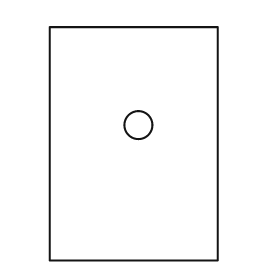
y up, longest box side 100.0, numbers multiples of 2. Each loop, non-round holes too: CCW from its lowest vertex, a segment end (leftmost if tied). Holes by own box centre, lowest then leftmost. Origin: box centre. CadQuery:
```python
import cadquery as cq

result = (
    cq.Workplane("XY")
    .moveTo(-36.0, -50.0)
    .lineTo(36.0, -50.0)
    .lineTo(36.0, 50.0)
    .lineTo(-36.0, 50.0)
    .close()
    .moveTo(2.0, 8.0)
    .circle(6.0)
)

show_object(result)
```